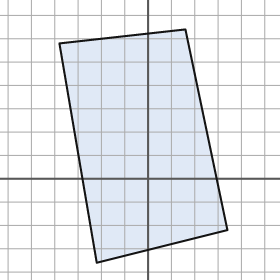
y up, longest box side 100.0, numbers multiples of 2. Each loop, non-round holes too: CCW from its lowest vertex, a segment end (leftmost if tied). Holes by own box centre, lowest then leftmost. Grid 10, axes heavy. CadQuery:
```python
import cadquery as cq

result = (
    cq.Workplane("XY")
    .moveTo(-22.0, -36.0)
    .lineTo(34.0, -22.0)
    .lineTo(16.0, 64.0)
    .lineTo(-38.0, 58.0)
    .close()
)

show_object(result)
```